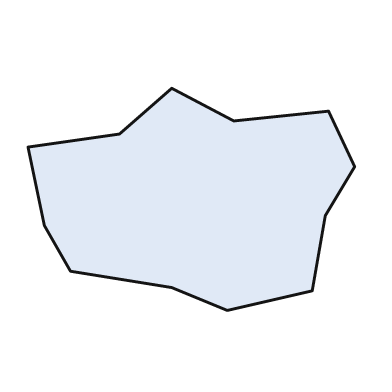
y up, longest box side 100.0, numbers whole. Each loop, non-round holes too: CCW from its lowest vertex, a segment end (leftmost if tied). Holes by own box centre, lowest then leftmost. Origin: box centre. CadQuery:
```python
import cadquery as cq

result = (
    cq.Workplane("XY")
    .moveTo(11.0, -34.0)
    .lineTo(37.0, -28.0)
    .lineTo(41.0, -5.0)
    .lineTo(50.0, 10.0)
    .lineTo(42.0, 27.0)
    .lineTo(13.0, 24.0)
    .lineTo(-6.0, 34.0)
    .lineTo(-22.0, 20.0)
    .lineTo(-50.0, 16.0)
    .lineTo(-45.0, -8.0)
    .lineTo(-37.0, -22.0)
    .lineTo(-6.0, -27.0)
    .close()
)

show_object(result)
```